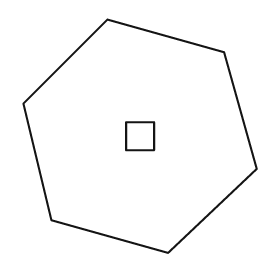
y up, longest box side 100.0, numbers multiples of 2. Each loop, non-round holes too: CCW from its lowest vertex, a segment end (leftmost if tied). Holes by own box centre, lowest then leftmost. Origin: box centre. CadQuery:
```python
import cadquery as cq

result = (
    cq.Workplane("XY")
    .moveTo(12.0, -50.0)
    .lineTo(50.0, -14.0)
    .lineTo(36.0, 36.0)
    .lineTo(-14.0, 50.0)
    .lineTo(-50.0, 14.0)
    .lineTo(-38.0, -36.0)
    .close()
    .moveTo(-6.0, -6.0)
    .lineTo(6.0, -6.0)
    .lineTo(6.0, 6.0)
    .lineTo(-6.0, 6.0)
    .close()
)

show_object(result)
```